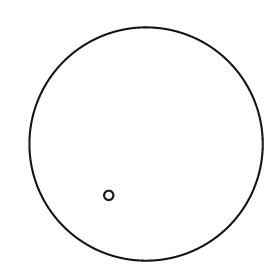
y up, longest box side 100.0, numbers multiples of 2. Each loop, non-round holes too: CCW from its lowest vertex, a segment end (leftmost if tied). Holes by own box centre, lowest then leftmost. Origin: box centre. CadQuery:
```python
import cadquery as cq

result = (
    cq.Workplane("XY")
    .moveTo(0.0, 0.0)
    .circle(50.0)
    .moveTo(-16.0, -22.0)
    .circle(2.0)
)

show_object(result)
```